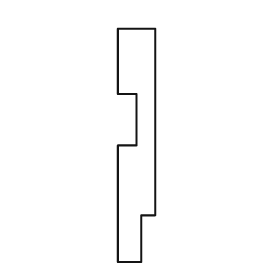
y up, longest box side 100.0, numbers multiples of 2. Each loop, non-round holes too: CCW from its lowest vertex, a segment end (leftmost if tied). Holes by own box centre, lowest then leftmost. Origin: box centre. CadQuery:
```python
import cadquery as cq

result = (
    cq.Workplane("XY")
    .moveTo(-8.0, -50.0)
    .lineTo(2.0, -50.0)
    .lineTo(2.0, -30.0)
    .lineTo(8.0, -30.0)
    .lineTo(8.0, 50.0)
    .lineTo(-8.0, 50.0)
    .lineTo(-8.0, 22.0)
    .lineTo(0.0, 22.0)
    .lineTo(0.0, 0.0)
    .lineTo(-8.0, 0.0)
    .close()
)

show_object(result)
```